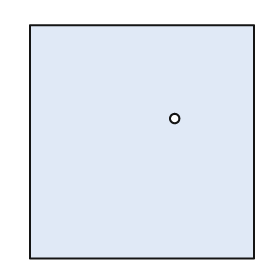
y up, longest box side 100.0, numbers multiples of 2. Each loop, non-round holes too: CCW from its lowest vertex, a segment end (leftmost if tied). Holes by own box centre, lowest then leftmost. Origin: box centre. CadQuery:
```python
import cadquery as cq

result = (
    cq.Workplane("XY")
    .moveTo(-48.0, -50.0)
    .lineTo(48.0, -50.0)
    .lineTo(48.0, 50.0)
    .lineTo(-48.0, 50.0)
    .close()
    .moveTo(14.0, 10.0)
    .circle(2.0)
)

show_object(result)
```